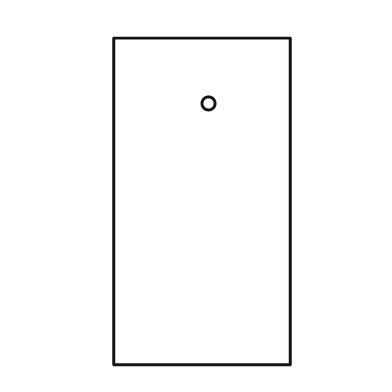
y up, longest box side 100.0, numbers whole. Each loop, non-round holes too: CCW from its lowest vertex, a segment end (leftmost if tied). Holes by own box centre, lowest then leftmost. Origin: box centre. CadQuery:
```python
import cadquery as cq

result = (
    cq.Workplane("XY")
    .moveTo(-27.0, -50.0)
    .lineTo(27.0, -50.0)
    .lineTo(27.0, 50.0)
    .lineTo(-27.0, 50.0)
    .close()
    .moveTo(2.0, 30.0)
    .circle(2.0)
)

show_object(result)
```